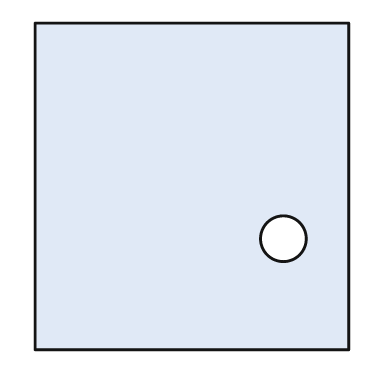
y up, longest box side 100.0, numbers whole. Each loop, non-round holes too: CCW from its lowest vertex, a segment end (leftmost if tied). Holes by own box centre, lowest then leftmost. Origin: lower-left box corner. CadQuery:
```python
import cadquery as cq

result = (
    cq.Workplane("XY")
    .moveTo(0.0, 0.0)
    .lineTo(96.0, 0.0)
    .lineTo(96.0, 100.0)
    .lineTo(0.0, 100.0)
    .close()
    .moveTo(76.0, 34.0)
    .circle(7.0)
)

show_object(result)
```